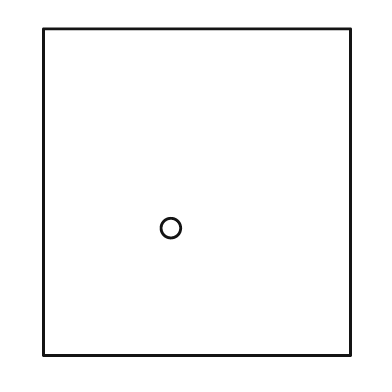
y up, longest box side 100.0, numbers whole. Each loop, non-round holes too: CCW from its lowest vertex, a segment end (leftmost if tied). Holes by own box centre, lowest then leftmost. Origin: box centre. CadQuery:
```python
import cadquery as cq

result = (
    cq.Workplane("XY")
    .moveTo(-47.0, -50.0)
    .lineTo(47.0, -50.0)
    .lineTo(47.0, 50.0)
    .lineTo(-47.0, 50.0)
    .close()
    .moveTo(-8.0, -11.0)
    .circle(3.0)
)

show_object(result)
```